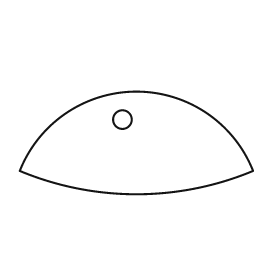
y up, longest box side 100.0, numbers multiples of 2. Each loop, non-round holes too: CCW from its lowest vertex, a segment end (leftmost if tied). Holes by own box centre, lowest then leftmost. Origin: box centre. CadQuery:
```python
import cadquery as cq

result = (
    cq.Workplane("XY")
    .moveTo(-50.0, -12.0)
    .threePointArc((0.0, -22.0), (50.0, -12.0))
    .threePointArc((0.0, 22.0), (-50.0, -12.0))
    .close()
    .moveTo(-6.0, 10.0)
    .circle(4.0)
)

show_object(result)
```